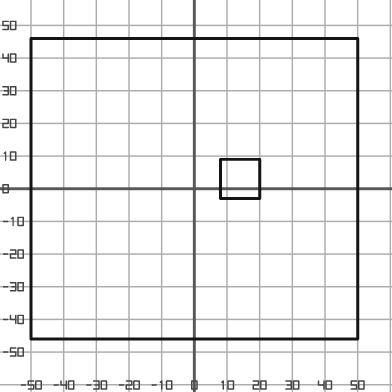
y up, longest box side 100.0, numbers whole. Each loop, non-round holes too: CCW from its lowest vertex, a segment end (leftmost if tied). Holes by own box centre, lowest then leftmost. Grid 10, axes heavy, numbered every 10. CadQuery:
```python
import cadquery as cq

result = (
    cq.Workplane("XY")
    .moveTo(-50.0, -46.0)
    .lineTo(50.0, -46.0)
    .lineTo(50.0, 46.0)
    .lineTo(-50.0, 46.0)
    .close()
    .moveTo(8.0, -3.0)
    .lineTo(20.0, -3.0)
    .lineTo(20.0, 9.0)
    .lineTo(8.0, 9.0)
    .close()
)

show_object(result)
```